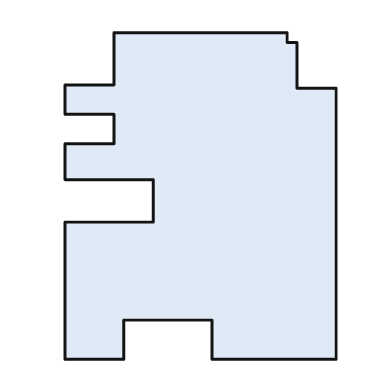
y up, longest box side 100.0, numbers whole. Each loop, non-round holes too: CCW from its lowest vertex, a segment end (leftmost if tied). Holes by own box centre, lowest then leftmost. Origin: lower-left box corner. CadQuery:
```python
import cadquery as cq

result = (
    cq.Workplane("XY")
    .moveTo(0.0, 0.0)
    .lineTo(18.0, 0.0)
    .lineTo(18.0, 12.0)
    .lineTo(45.0, 12.0)
    .lineTo(45.0, 0.0)
    .lineTo(83.0, 0.0)
    .lineTo(83.0, 83.0)
    .lineTo(71.0, 83.0)
    .lineTo(71.0, 97.0)
    .lineTo(68.0, 97.0)
    .lineTo(68.0, 100.0)
    .lineTo(15.0, 100.0)
    .lineTo(15.0, 84.0)
    .lineTo(0.0, 84.0)
    .lineTo(0.0, 75.0)
    .lineTo(15.0, 75.0)
    .lineTo(15.0, 66.0)
    .lineTo(0.0, 66.0)
    .lineTo(0.0, 55.0)
    .lineTo(27.0, 55.0)
    .lineTo(27.0, 42.0)
    .lineTo(0.0, 42.0)
    .close()
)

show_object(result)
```